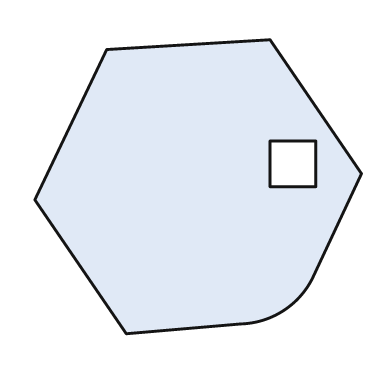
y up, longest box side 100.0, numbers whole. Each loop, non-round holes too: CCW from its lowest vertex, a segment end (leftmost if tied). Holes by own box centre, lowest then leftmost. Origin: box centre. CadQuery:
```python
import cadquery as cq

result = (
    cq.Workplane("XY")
    .moveTo(-22.0, -45.0)
    .lineTo(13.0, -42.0)
    .threePointArc((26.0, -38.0), (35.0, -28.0))
    .lineTo(50.0, 4.0)
    .lineTo(22.0, 45.0)
    .lineTo(-28.0, 42.0)
    .lineTo(-50.0, -4.0)
    .close()
    .moveTo(22.0, 0.0)
    .lineTo(36.0, 0.0)
    .lineTo(36.0, 14.0)
    .lineTo(22.0, 14.0)
    .close()
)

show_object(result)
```